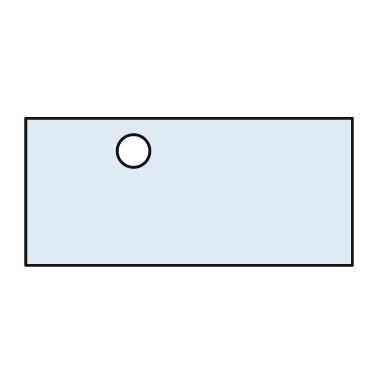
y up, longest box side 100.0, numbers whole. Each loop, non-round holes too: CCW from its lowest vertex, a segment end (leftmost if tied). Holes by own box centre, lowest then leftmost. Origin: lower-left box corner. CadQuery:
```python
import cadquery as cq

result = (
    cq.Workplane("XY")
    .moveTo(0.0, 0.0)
    .lineTo(100.0, 0.0)
    .lineTo(100.0, 45.0)
    .lineTo(0.0, 45.0)
    .close()
    .moveTo(33.0, 35.0)
    .circle(5.0)
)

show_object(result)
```